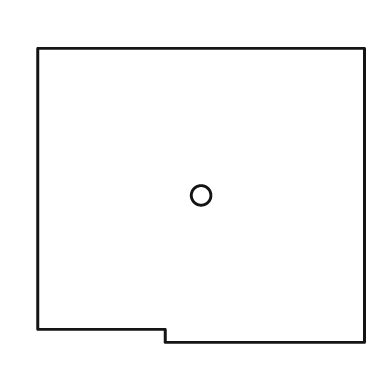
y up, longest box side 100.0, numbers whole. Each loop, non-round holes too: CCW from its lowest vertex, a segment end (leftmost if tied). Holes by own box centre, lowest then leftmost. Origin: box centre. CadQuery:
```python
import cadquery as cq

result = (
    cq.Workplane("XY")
    .moveTo(-11.0, -45.0)
    .lineTo(50.0, -45.0)
    .lineTo(50.0, 45.0)
    .lineTo(-50.0, 45.0)
    .lineTo(-50.0, -41.0)
    .lineTo(-11.0, -41.0)
    .close()
    .moveTo(0.0, 0.0)
    .circle(3.0)
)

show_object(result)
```